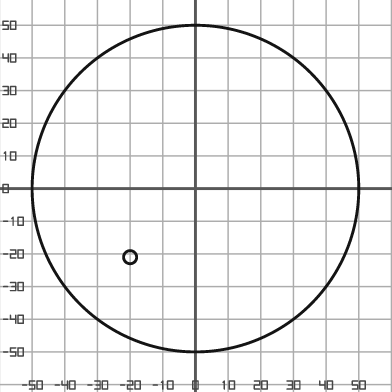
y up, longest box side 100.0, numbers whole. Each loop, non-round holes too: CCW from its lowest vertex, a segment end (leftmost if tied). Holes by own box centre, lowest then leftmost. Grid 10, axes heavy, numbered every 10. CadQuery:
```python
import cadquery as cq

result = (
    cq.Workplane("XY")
    .moveTo(0.0, 0.0)
    .circle(50.0)
    .moveTo(-20.0, -21.0)
    .circle(2.0)
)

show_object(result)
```